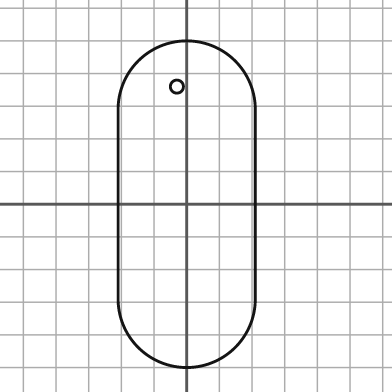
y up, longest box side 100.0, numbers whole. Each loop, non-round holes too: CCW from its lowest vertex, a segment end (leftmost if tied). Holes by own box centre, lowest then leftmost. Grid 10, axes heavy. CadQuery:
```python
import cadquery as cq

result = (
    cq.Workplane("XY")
    .moveTo(-21.0, -29.0)
    .threePointArc((0.0, -50.0), (21.0, -29.0))
    .lineTo(21.0, 29.0)
    .threePointArc((0.0, 50.0), (-21.0, 29.0))
    .close()
    .moveTo(-3.0, 36.0)
    .circle(2.0)
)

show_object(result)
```